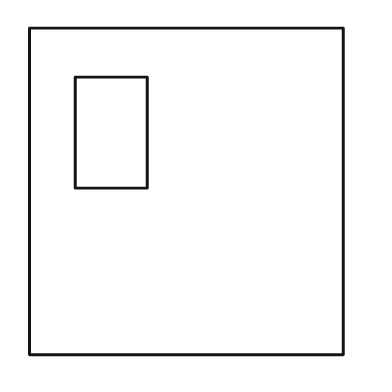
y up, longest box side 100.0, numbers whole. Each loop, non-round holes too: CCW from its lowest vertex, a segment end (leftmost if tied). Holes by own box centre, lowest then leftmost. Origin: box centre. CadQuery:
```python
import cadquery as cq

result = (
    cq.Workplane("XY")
    .moveTo(-48.0, -50.0)
    .lineTo(48.0, -50.0)
    .lineTo(48.0, 50.0)
    .lineTo(-48.0, 50.0)
    .close()
    .moveTo(-34.0, 1.0)
    .lineTo(-12.0, 1.0)
    .lineTo(-12.0, 35.0)
    .lineTo(-34.0, 35.0)
    .close()
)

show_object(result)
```